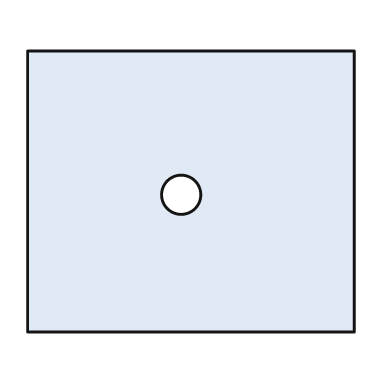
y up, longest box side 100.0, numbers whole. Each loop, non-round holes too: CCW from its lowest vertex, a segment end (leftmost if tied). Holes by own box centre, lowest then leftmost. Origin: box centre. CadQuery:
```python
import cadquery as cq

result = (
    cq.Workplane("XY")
    .moveTo(-50.0, -43.0)
    .lineTo(50.0, -43.0)
    .lineTo(50.0, 43.0)
    .lineTo(-50.0, 43.0)
    .close()
    .moveTo(-3.0, -1.0)
    .circle(6.0)
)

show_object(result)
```